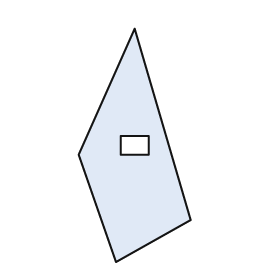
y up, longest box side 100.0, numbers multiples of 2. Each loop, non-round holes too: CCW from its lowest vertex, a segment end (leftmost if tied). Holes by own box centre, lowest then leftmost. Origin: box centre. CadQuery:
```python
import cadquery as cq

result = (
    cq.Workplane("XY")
    .moveTo(-8.0, -50.0)
    .lineTo(24.0, -32.0)
    .lineTo(0.0, 50.0)
    .lineTo(-24.0, -4.0)
    .close()
    .moveTo(-6.0, -4.0)
    .lineTo(6.0, -4.0)
    .lineTo(6.0, 4.0)
    .lineTo(-6.0, 4.0)
    .close()
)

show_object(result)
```